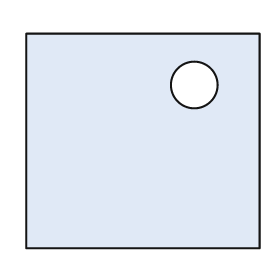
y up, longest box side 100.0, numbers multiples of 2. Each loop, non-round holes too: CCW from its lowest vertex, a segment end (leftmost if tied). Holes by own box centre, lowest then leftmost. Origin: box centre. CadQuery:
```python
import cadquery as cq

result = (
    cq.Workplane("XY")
    .moveTo(-50.0, -46.0)
    .lineTo(50.0, -46.0)
    .lineTo(50.0, 46.0)
    .lineTo(-50.0, 46.0)
    .close()
    .moveTo(22.0, 24.0)
    .circle(10.0)
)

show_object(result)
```